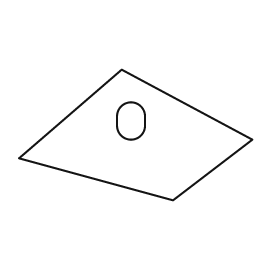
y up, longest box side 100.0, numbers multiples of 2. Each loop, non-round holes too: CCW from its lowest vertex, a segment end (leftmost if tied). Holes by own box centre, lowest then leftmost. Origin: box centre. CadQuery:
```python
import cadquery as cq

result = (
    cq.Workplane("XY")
    .moveTo(16.0, -28.0)
    .lineTo(50.0, -2.0)
    .lineTo(-6.0, 28.0)
    .lineTo(-50.0, -10.0)
    .close()
    .moveTo(-8.0, 4.0)
    .threePointArc((-2.0, -2.0), (4.0, 4.0))
    .lineTo(4.0, 8.0)
    .threePointArc((-2.0, 14.0), (-8.0, 8.0))
    .close()
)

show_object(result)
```